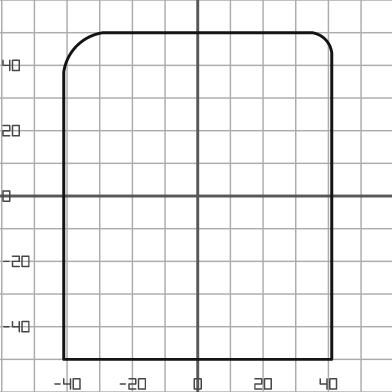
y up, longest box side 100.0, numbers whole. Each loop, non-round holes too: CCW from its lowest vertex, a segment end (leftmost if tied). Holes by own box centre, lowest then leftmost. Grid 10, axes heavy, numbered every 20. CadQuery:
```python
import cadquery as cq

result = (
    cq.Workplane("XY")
    .moveTo(-41.0, -50.0)
    .lineTo(41.0, -50.0)
    .lineTo(41.0, 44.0)
    .threePointArc((39.0, 48.0), (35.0, 50.0))
    .lineTo(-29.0, 50.0)
    .threePointArc((-37.0, 46.0), (-41.0, 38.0))
    .close()
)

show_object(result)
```